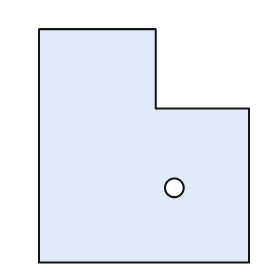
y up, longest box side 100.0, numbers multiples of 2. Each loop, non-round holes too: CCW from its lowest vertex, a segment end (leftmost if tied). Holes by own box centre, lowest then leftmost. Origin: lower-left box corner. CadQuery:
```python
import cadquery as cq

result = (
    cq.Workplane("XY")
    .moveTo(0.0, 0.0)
    .lineTo(90.0, 0.0)
    .lineTo(90.0, 66.0)
    .lineTo(50.0, 66.0)
    .lineTo(50.0, 100.0)
    .lineTo(0.0, 100.0)
    .close()
    .moveTo(58.0, 32.0)
    .circle(4.0)
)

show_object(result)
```